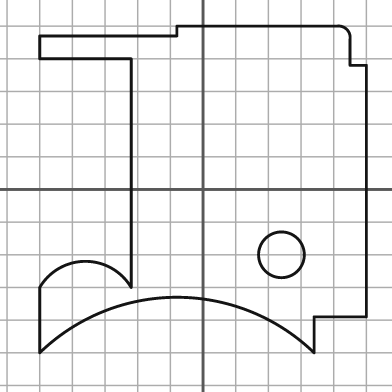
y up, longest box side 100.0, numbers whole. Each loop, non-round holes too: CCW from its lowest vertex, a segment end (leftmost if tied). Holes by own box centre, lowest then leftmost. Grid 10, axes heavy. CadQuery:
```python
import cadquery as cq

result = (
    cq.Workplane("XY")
    .moveTo(-50.0, -50.0)
    .threePointArc((-8.0, -33.0), (34.0, -50.0))
    .lineTo(34.0, -39.0)
    .lineTo(50.0, -39.0)
    .lineTo(50.0, 38.0)
    .lineTo(45.0, 38.0)
    .lineTo(45.0, 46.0)
    .threePointArc((44.0, 49.0), (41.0, 50.0))
    .lineTo(-8.0, 50.0)
    .lineTo(-8.0, 47.0)
    .lineTo(-50.0, 47.0)
    .lineTo(-50.0, 40.0)
    .lineTo(-22.0, 40.0)
    .lineTo(-22.0, -30.0)
    .threePointArc((-36.0, -22.0), (-50.0, -30.0))
    .close()
    .moveTo(24.0, -20.0)
    .circle(7.0)
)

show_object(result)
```